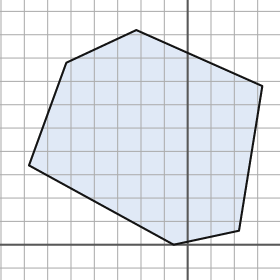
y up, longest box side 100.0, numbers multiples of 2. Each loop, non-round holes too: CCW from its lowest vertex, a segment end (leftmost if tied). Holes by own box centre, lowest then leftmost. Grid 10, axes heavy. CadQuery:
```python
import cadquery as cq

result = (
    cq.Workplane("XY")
    .moveTo(-6.0, 0.0)
    .lineTo(22.0, 6.0)
    .lineTo(32.0, 68.0)
    .lineTo(-22.0, 92.0)
    .lineTo(-52.0, 78.0)
    .lineTo(-68.0, 34.0)
    .close()
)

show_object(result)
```